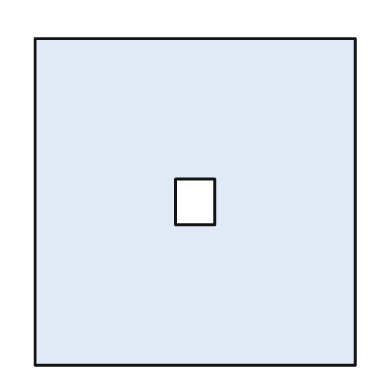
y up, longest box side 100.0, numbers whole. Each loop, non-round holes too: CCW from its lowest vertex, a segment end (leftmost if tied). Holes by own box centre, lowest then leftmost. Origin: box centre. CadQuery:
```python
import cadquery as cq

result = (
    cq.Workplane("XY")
    .moveTo(-49.0, -50.0)
    .lineTo(49.0, -50.0)
    .lineTo(49.0, 50.0)
    .lineTo(-49.0, 50.0)
    .close()
    .moveTo(-6.0, -7.0)
    .lineTo(6.0, -7.0)
    .lineTo(6.0, 7.0)
    .lineTo(-6.0, 7.0)
    .close()
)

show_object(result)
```